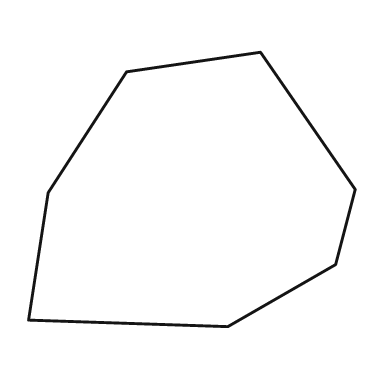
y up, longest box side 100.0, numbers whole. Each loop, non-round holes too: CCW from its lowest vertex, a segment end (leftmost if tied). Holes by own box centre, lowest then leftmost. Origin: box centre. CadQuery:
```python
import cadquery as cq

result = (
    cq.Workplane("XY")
    .moveTo(11.0, -42.0)
    .lineTo(44.0, -23.0)
    .lineTo(50.0, 0.0)
    .lineTo(21.0, 42.0)
    .lineTo(-20.0, 36.0)
    .lineTo(-44.0, -1.0)
    .lineTo(-50.0, -40.0)
    .close()
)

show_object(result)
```